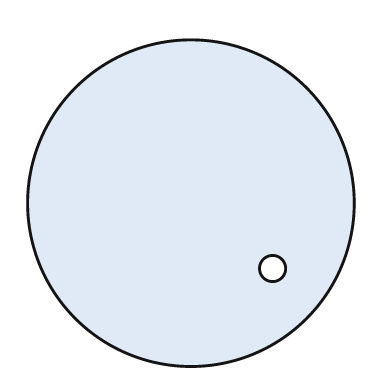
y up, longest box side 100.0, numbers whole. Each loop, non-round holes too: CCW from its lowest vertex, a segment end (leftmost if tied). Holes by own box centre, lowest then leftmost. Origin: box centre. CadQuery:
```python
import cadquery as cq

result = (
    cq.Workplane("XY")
    .moveTo(0.0, 0.0)
    .circle(50.0)
    .moveTo(25.0, -20.0)
    .circle(4.0)
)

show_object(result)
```